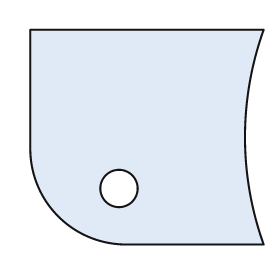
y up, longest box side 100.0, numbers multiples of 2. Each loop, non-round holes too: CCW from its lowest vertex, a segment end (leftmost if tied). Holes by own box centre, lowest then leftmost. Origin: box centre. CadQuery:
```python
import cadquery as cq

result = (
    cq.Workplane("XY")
    .moveTo(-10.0, -46.0)
    .lineTo(50.0, -46.0)
    .threePointArc((42.0, 0.0), (50.0, 46.0))
    .lineTo(-50.0, 46.0)
    .lineTo(-50.0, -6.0)
    .threePointArc((-38.0, -34.0), (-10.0, -46.0))
    .close()
    .moveTo(-12.0, -22.0)
    .circle(8.0)
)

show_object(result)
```